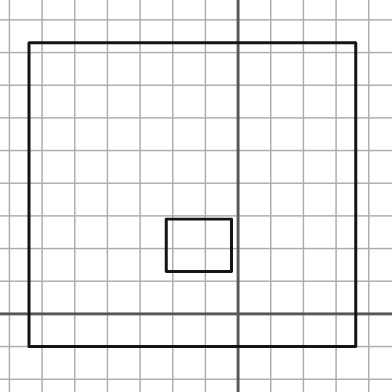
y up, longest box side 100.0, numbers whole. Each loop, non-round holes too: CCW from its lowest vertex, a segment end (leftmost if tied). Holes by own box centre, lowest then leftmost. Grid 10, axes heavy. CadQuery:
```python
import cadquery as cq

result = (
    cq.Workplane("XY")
    .moveTo(-64.0, -10.0)
    .lineTo(36.0, -10.0)
    .lineTo(36.0, 83.0)
    .lineTo(-64.0, 83.0)
    .close()
    .moveTo(-22.0, 13.0)
    .lineTo(-2.0, 13.0)
    .lineTo(-2.0, 29.0)
    .lineTo(-22.0, 29.0)
    .close()
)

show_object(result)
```